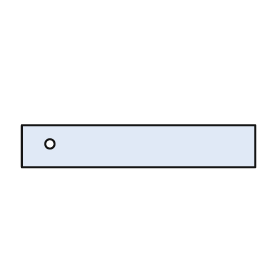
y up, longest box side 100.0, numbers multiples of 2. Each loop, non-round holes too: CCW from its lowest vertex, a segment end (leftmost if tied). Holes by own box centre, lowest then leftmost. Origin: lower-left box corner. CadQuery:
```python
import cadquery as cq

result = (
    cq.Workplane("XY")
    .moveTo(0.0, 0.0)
    .lineTo(100.0, 0.0)
    .lineTo(100.0, 18.0)
    .lineTo(0.0, 18.0)
    .close()
    .moveTo(12.0, 10.0)
    .circle(2.0)
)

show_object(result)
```